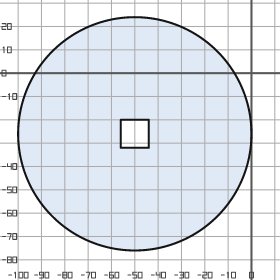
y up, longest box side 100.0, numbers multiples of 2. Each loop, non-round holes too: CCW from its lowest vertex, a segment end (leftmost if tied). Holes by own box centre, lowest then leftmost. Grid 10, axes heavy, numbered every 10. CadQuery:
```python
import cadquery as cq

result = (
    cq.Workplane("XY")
    .moveTo(-50.0, -26.0)
    .circle(50.0)
    .moveTo(-56.0, -32.0)
    .lineTo(-44.0, -32.0)
    .lineTo(-44.0, -20.0)
    .lineTo(-56.0, -20.0)
    .close()
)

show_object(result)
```